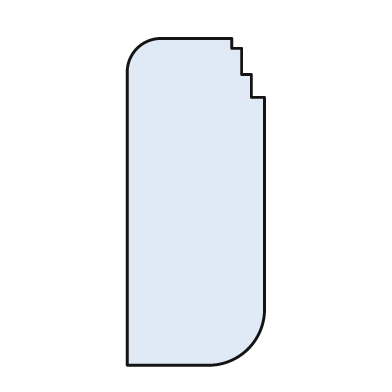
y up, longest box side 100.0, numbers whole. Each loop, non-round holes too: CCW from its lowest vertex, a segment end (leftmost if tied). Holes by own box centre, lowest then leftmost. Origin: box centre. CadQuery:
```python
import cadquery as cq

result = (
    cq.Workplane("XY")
    .moveTo(-21.0, -50.0)
    .lineTo(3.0, -50.0)
    .threePointArc((16.0, -45.0), (21.0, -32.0))
    .lineTo(21.0, 32.0)
    .lineTo(17.0, 32.0)
    .lineTo(17.0, 39.0)
    .lineTo(14.0, 39.0)
    .lineTo(14.0, 47.0)
    .lineTo(11.0, 47.0)
    .lineTo(11.0, 50.0)
    .lineTo(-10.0, 50.0)
    .threePointArc((-18.0, 47.0), (-21.0, 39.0))
    .close()
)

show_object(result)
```